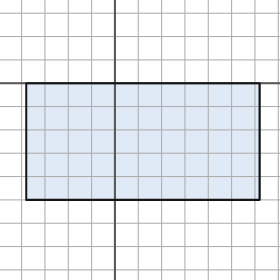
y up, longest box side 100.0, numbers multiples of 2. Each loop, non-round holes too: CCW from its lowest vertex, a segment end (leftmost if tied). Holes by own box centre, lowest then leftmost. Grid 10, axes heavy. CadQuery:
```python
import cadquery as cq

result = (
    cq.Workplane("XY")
    .moveTo(-38.0, -50.0)
    .lineTo(62.0, -50.0)
    .lineTo(62.0, 0.0)
    .lineTo(-38.0, 0.0)
    .close()
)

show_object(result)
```